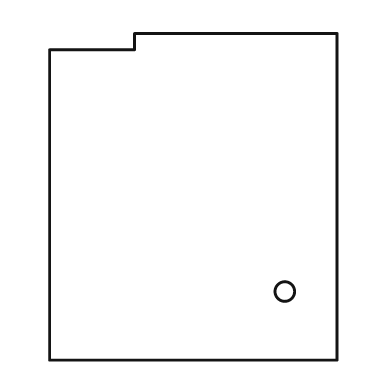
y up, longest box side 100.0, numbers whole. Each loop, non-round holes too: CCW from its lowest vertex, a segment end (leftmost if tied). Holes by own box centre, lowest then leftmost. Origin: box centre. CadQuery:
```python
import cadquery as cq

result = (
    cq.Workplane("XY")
    .moveTo(-44.0, -50.0)
    .lineTo(44.0, -50.0)
    .lineTo(44.0, 50.0)
    .lineTo(-18.0, 50.0)
    .lineTo(-18.0, 45.0)
    .lineTo(-44.0, 45.0)
    .close()
    .moveTo(28.0, -29.0)
    .circle(3.0)
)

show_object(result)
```